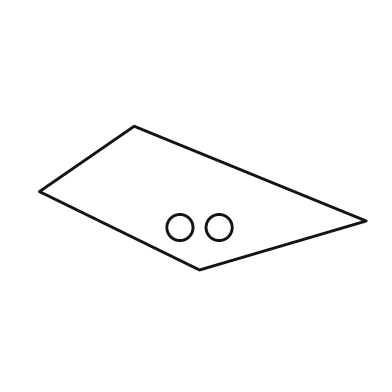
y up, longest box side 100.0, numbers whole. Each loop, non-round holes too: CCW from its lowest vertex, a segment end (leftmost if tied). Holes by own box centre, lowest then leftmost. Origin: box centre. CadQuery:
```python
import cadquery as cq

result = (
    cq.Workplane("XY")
    .moveTo(-1.0, -22.0)
    .lineTo(50.0, -7.0)
    .lineTo(-21.0, 22.0)
    .lineTo(-50.0, 2.0)
    .close()
    .moveTo(-7.0, -9.0)
    .circle(4.0)
    .moveTo(5.0, -9.0)
    .circle(4.0)
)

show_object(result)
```